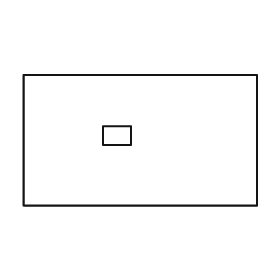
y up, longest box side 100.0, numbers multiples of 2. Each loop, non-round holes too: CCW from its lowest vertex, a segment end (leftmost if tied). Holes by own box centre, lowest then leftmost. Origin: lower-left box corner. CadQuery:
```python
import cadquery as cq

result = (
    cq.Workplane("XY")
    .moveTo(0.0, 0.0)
    .lineTo(100.0, 0.0)
    .lineTo(100.0, 56.0)
    .lineTo(0.0, 56.0)
    .close()
    .moveTo(34.0, 26.0)
    .lineTo(46.0, 26.0)
    .lineTo(46.0, 34.0)
    .lineTo(34.0, 34.0)
    .close()
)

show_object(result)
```